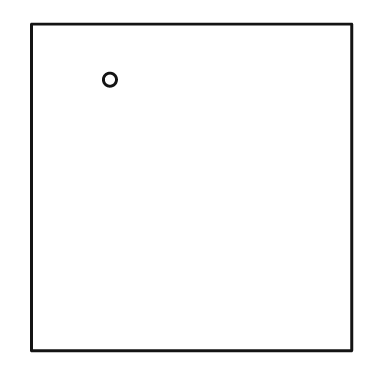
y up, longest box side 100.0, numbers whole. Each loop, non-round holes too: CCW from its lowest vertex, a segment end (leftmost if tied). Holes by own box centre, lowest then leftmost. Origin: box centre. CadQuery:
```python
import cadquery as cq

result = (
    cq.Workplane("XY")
    .moveTo(-49.0, -50.0)
    .lineTo(49.0, -50.0)
    .lineTo(49.0, 50.0)
    .lineTo(-49.0, 50.0)
    .close()
    .moveTo(-25.0, 33.0)
    .circle(2.0)
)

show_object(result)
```